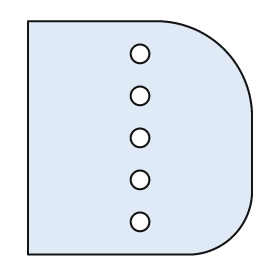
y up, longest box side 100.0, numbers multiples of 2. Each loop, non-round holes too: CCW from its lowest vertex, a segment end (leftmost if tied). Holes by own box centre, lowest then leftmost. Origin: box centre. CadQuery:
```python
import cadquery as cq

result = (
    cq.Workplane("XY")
    .moveTo(-48.0, -50.0)
    .lineTo(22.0, -50.0)
    .threePointArc((40.0, -42.0), (48.0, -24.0))
    .lineTo(48.0, 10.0)
    .threePointArc((36.0, 38.0), (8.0, 50.0))
    .lineTo(-48.0, 50.0)
    .close()
    .moveTo(0.0, -36.0)
    .circle(4.0)
    .moveTo(0.0, -18.0)
    .circle(4.0)
    .moveTo(0.0, 0.0)
    .circle(4.0)
    .moveTo(0.0, 18.0)
    .circle(4.0)
    .moveTo(0.0, 36.0)
    .circle(4.0)
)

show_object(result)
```